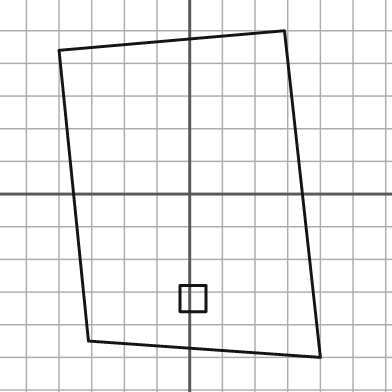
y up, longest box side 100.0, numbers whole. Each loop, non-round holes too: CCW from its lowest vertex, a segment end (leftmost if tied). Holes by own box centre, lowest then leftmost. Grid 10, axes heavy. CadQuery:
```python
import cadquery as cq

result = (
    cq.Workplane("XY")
    .moveTo(40.0, -50.0)
    .lineTo(29.0, 50.0)
    .lineTo(-40.0, 44.0)
    .lineTo(-31.0, -45.0)
    .close()
    .moveTo(-3.0, -36.0)
    .lineTo(5.0, -36.0)
    .lineTo(5.0, -28.0)
    .lineTo(-3.0, -28.0)
    .close()
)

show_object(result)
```